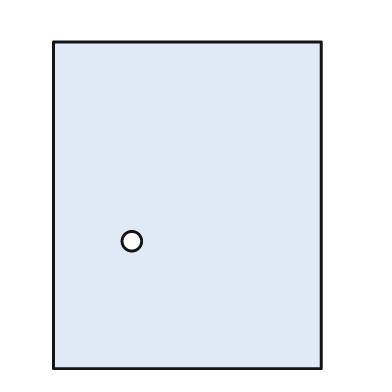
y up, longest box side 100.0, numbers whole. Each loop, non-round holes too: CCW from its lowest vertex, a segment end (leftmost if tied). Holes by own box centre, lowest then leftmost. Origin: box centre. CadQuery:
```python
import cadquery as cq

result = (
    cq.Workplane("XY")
    .moveTo(-41.0, -50.0)
    .lineTo(41.0, -50.0)
    .lineTo(41.0, 50.0)
    .lineTo(-41.0, 50.0)
    .close()
    .moveTo(-17.0, -11.0)
    .circle(3.0)
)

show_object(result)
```